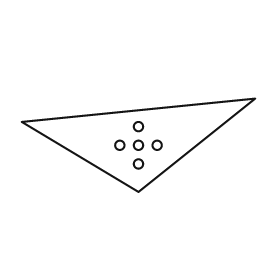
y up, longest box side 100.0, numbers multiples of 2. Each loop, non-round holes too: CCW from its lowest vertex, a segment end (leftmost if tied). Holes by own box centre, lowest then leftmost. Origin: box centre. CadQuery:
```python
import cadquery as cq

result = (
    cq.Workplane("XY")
    .moveTo(0.0, -20.0)
    .lineTo(50.0, 20.0)
    .lineTo(-50.0, 10.0)
    .close()
    .moveTo(0.0, -8.0)
    .circle(2.0)
    .moveTo(-8.0, 0.0)
    .circle(2.0)
    .moveTo(0.0, 0.0)
    .circle(2.0)
    .moveTo(8.0, 0.0)
    .circle(2.0)
    .moveTo(0.0, 8.0)
    .circle(2.0)
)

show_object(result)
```